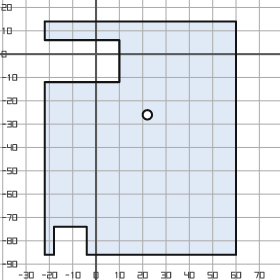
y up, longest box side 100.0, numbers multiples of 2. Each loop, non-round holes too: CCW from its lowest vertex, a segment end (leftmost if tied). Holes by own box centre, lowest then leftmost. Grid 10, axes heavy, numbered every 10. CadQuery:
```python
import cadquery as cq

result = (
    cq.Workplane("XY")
    .moveTo(-22.0, -86.0)
    .lineTo(-18.0, -86.0)
    .lineTo(-18.0, -74.0)
    .lineTo(-4.0, -74.0)
    .lineTo(-4.0, -86.0)
    .lineTo(60.0, -86.0)
    .lineTo(60.0, 14.0)
    .lineTo(-22.0, 14.0)
    .lineTo(-22.0, 6.0)
    .lineTo(10.0, 6.0)
    .lineTo(10.0, -12.0)
    .lineTo(-22.0, -12.0)
    .close()
    .moveTo(22.0, -26.0)
    .circle(2.0)
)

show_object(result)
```